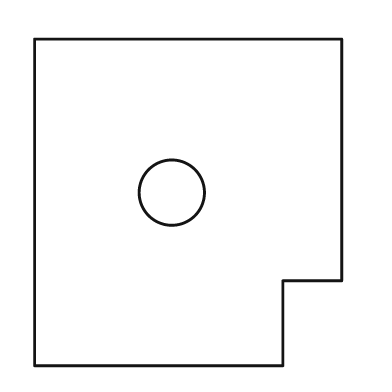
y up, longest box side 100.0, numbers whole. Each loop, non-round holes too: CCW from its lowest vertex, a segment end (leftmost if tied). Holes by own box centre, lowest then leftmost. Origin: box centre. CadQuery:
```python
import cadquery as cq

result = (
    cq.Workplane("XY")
    .moveTo(-47.0, -50.0)
    .lineTo(29.0, -50.0)
    .lineTo(29.0, -24.0)
    .lineTo(47.0, -24.0)
    .lineTo(47.0, 50.0)
    .lineTo(-47.0, 50.0)
    .close()
    .moveTo(-5.0, 3.0)
    .circle(10.0)
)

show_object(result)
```